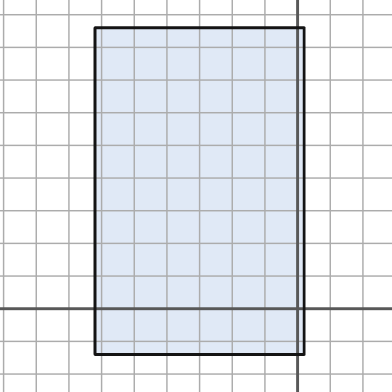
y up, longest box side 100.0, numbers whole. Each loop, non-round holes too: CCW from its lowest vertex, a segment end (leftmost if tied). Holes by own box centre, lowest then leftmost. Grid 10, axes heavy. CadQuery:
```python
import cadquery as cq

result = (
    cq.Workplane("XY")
    .moveTo(-62.0, -14.0)
    .lineTo(2.0, -14.0)
    .lineTo(2.0, 86.0)
    .lineTo(-62.0, 86.0)
    .close()
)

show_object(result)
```